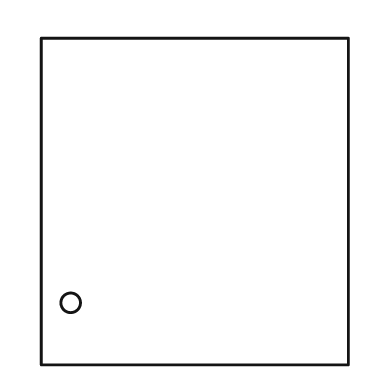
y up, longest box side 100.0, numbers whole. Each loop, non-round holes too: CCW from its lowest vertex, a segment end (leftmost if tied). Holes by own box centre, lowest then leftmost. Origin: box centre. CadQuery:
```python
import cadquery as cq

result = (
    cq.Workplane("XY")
    .moveTo(-47.0, -50.0)
    .lineTo(47.0, -50.0)
    .lineTo(47.0, 50.0)
    .lineTo(-47.0, 50.0)
    .close()
    .moveTo(-38.0, -31.0)
    .circle(3.0)
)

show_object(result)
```